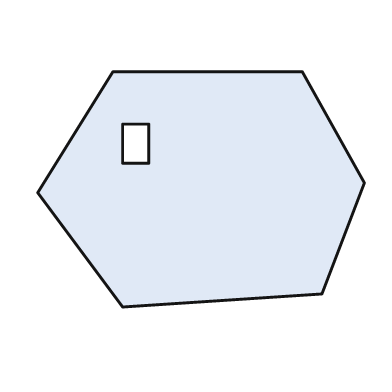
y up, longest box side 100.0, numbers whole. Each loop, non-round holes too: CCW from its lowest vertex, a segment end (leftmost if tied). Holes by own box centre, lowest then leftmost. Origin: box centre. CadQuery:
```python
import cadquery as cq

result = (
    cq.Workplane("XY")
    .moveTo(-24.0, -36.0)
    .lineTo(37.0, -32.0)
    .lineTo(50.0, 2.0)
    .lineTo(31.0, 36.0)
    .lineTo(-27.0, 36.0)
    .lineTo(-50.0, -1.0)
    .close()
    .moveTo(-24.0, 8.0)
    .lineTo(-16.0, 8.0)
    .lineTo(-16.0, 20.0)
    .lineTo(-24.0, 20.0)
    .close()
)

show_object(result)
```